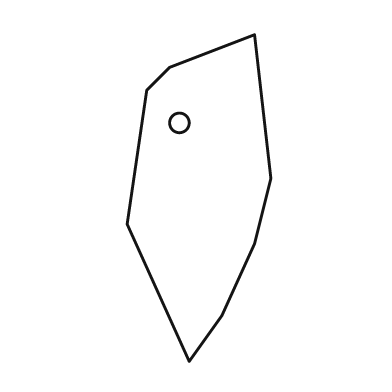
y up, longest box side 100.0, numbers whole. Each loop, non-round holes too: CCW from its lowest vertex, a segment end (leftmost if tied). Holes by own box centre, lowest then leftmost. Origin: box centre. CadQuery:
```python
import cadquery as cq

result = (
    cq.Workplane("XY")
    .moveTo(-3.0, -50.0)
    .lineTo(7.0, -36.0)
    .lineTo(17.0, -14.0)
    .lineTo(22.0, 6.0)
    .lineTo(17.0, 50.0)
    .lineTo(-9.0, 40.0)
    .lineTo(-16.0, 33.0)
    .lineTo(-22.0, -8.0)
    .close()
    .moveTo(-6.0, 23.0)
    .circle(3.0)
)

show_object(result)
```